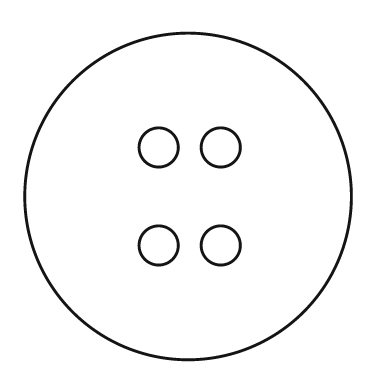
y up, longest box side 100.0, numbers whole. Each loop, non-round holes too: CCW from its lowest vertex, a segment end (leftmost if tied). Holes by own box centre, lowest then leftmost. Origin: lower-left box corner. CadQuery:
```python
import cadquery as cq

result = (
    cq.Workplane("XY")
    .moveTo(50.0, 50.0)
    .circle(50.0)
    .moveTo(41.0, 35.0)
    .circle(6.0)
    .moveTo(60.0, 35.0)
    .circle(6.0)
    .moveTo(41.0, 65.0)
    .circle(6.0)
    .moveTo(60.0, 65.0)
    .circle(6.0)
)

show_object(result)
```